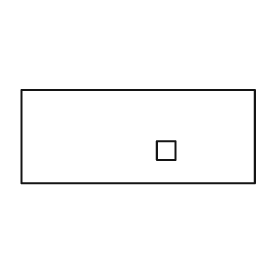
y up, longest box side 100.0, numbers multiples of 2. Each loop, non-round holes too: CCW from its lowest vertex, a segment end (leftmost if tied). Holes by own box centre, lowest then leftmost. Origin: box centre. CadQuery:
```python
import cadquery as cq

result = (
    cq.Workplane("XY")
    .moveTo(-50.0, -20.0)
    .lineTo(50.0, -20.0)
    .lineTo(50.0, 20.0)
    .lineTo(-50.0, 20.0)
    .close()
    .moveTo(8.0, -10.0)
    .lineTo(16.0, -10.0)
    .lineTo(16.0, -2.0)
    .lineTo(8.0, -2.0)
    .close()
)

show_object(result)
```